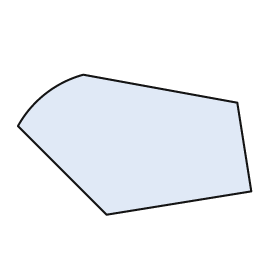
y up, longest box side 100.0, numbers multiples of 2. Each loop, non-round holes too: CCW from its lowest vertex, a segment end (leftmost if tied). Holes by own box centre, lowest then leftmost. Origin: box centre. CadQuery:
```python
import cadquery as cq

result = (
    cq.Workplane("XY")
    .moveTo(-12.0, -30.0)
    .lineTo(50.0, -20.0)
    .lineTo(44.0, 18.0)
    .lineTo(-22.0, 30.0)
    .threePointArc((-38.0, 22.0), (-50.0, 8.0))
    .close()
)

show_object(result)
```